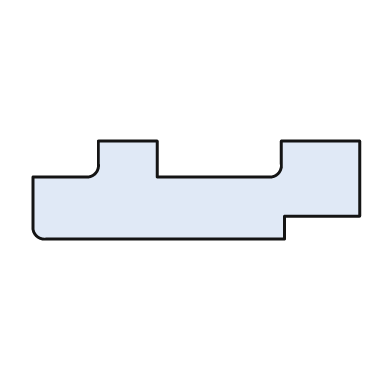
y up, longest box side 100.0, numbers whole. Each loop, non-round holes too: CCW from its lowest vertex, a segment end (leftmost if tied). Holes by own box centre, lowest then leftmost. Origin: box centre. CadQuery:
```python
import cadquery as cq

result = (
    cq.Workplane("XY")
    .moveTo(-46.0, -15.0)
    .lineTo(27.0, -15.0)
    .lineTo(27.0, -8.0)
    .lineTo(50.0, -8.0)
    .lineTo(50.0, 15.0)
    .lineTo(26.0, 15.0)
    .lineTo(26.0, 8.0)
    .threePointArc((25.0, 5.0), (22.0, 4.0))
    .lineTo(-12.0, 4.0)
    .lineTo(-12.0, 15.0)
    .lineTo(-30.0, 15.0)
    .lineTo(-30.0, 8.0)
    .threePointArc((-31.0, 5.0), (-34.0, 4.0))
    .lineTo(-50.0, 4.0)
    .lineTo(-50.0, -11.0)
    .threePointArc((-49.0, -14.0), (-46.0, -15.0))
    .close()
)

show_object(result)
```